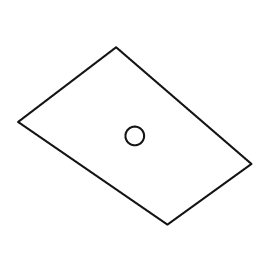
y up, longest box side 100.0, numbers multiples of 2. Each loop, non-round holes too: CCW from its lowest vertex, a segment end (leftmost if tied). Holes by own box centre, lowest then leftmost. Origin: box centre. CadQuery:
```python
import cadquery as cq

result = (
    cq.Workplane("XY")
    .moveTo(14.0, -38.0)
    .lineTo(50.0, -12.0)
    .lineTo(-8.0, 38.0)
    .lineTo(-50.0, 6.0)
    .close()
    .moveTo(0.0, 0.0)
    .circle(4.0)
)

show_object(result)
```